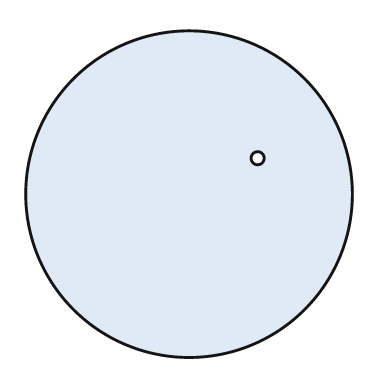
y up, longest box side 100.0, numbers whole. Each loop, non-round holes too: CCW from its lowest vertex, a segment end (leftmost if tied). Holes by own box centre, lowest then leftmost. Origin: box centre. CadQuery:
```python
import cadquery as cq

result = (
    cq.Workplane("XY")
    .moveTo(0.0, 0.0)
    .circle(50.0)
    .moveTo(21.0, 11.0)
    .circle(2.0)
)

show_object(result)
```